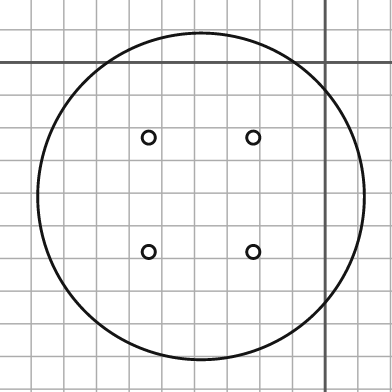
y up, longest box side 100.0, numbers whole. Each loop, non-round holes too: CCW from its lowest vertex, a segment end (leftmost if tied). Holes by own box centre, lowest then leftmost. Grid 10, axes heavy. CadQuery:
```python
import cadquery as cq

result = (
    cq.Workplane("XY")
    .moveTo(-38.0, -41.0)
    .circle(50.0)
    .moveTo(-54.0, -58.0)
    .circle(2.0)
    .moveTo(-22.0, -58.0)
    .circle(2.0)
    .moveTo(-54.0, -23.0)
    .circle(2.0)
    .moveTo(-22.0, -23.0)
    .circle(2.0)
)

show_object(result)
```